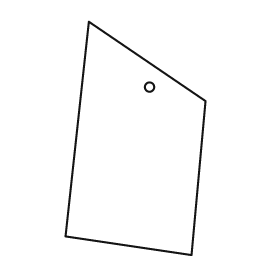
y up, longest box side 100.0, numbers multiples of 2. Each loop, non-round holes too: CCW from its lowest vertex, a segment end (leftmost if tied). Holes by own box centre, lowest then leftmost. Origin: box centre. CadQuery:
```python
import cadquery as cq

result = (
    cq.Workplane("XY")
    .moveTo(24.0, -50.0)
    .lineTo(30.0, 16.0)
    .lineTo(-20.0, 50.0)
    .lineTo(-30.0, -42.0)
    .close()
    .moveTo(6.0, 22.0)
    .circle(2.0)
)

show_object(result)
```